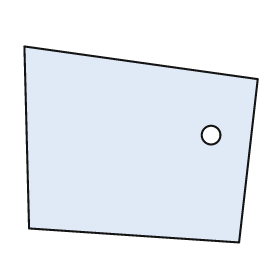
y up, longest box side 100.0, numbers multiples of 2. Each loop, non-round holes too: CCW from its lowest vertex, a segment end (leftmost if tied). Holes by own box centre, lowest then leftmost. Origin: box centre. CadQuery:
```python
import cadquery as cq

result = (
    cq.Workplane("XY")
    .moveTo(42.0, -42.0)
    .lineTo(50.0, 28.0)
    .lineTo(-50.0, 42.0)
    .lineTo(-48.0, -36.0)
    .close()
    .moveTo(30.0, 4.0)
    .circle(4.0)
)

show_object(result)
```